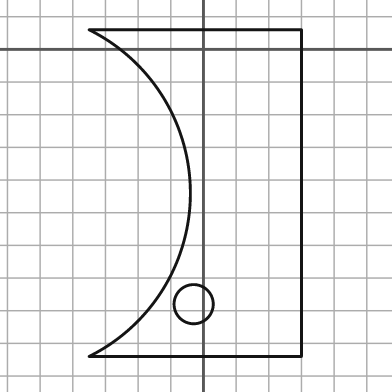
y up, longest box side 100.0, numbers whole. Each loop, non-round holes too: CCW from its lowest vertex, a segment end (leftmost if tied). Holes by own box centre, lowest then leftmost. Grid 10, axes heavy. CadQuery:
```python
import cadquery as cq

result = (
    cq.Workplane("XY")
    .moveTo(-35.0, -94.0)
    .lineTo(30.0, -94.0)
    .lineTo(30.0, 6.0)
    .lineTo(-35.0, 6.0)
    .threePointArc((-4.0, -44.0), (-35.0, -94.0))
    .close()
    .moveTo(-3.0, -78.0)
    .circle(6.0)
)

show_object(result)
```